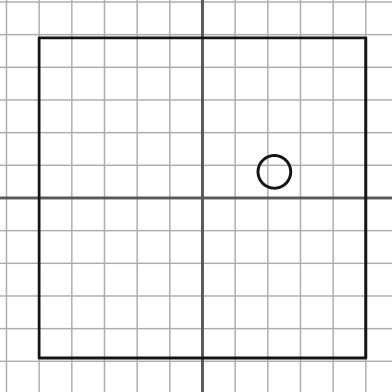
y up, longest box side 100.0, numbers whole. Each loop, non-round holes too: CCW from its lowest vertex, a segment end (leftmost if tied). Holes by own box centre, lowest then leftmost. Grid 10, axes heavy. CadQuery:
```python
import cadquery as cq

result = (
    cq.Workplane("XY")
    .moveTo(-50.0, -49.0)
    .lineTo(50.0, -49.0)
    .lineTo(50.0, 49.0)
    .lineTo(-50.0, 49.0)
    .close()
    .moveTo(22.0, 8.0)
    .circle(5.0)
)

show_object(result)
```